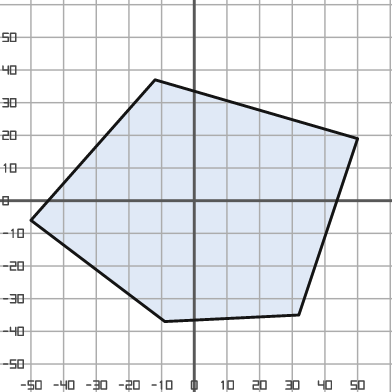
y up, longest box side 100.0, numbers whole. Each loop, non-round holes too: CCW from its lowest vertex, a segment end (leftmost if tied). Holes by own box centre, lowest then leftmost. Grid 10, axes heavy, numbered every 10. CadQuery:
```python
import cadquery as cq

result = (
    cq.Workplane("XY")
    .moveTo(-9.0, -37.0)
    .lineTo(32.0, -35.0)
    .lineTo(50.0, 19.0)
    .lineTo(-12.0, 37.0)
    .lineTo(-50.0, -6.0)
    .close()
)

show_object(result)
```